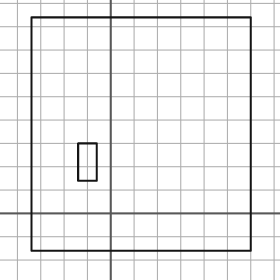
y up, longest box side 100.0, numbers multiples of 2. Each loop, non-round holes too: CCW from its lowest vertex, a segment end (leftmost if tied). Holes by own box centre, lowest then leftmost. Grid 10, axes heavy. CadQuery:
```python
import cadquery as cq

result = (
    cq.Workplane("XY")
    .moveTo(-34.0, -16.0)
    .lineTo(60.0, -16.0)
    .lineTo(60.0, 84.0)
    .lineTo(-34.0, 84.0)
    .close()
    .moveTo(-14.0, 14.0)
    .lineTo(-6.0, 14.0)
    .lineTo(-6.0, 30.0)
    .lineTo(-14.0, 30.0)
    .close()
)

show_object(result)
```